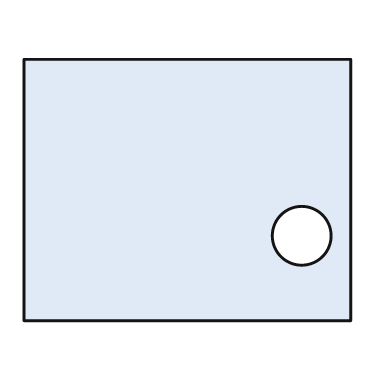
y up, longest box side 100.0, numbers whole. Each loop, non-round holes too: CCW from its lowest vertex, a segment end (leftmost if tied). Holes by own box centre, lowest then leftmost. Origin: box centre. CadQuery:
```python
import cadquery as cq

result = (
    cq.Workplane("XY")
    .moveTo(-50.0, -40.0)
    .lineTo(50.0, -40.0)
    .lineTo(50.0, 40.0)
    .lineTo(-50.0, 40.0)
    .close()
    .moveTo(35.0, -14.0)
    .circle(9.0)
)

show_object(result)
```